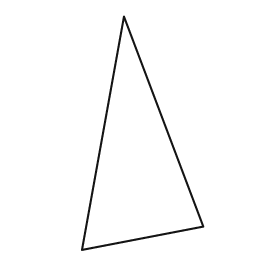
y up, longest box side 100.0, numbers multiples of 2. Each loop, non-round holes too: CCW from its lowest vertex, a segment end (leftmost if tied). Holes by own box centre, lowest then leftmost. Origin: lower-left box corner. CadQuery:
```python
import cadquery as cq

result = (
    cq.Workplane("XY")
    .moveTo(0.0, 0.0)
    .lineTo(52.0, 10.0)
    .lineTo(18.0, 100.0)
    .close()
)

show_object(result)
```